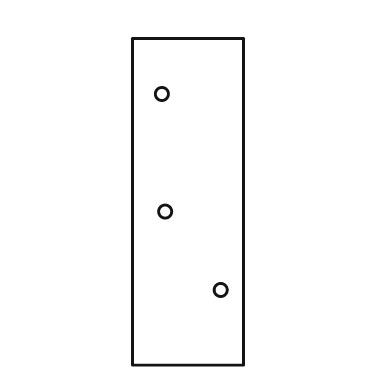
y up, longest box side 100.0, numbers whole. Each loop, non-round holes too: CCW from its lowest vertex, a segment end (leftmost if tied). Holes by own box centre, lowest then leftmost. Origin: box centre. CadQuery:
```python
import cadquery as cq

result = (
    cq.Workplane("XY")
    .moveTo(-17.0, -50.0)
    .lineTo(17.0, -50.0)
    .lineTo(17.0, 50.0)
    .lineTo(-17.0, 50.0)
    .close()
    .moveTo(10.0, -27.0)
    .circle(2.0)
    .moveTo(-7.0, -3.0)
    .circle(2.0)
    .moveTo(-8.0, 33.0)
    .circle(2.0)
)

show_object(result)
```